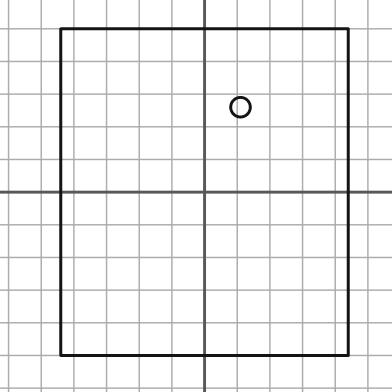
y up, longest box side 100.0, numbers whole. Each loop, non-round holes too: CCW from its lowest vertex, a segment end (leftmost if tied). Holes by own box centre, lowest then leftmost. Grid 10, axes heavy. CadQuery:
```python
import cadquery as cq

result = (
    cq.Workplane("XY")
    .moveTo(-44.0, -50.0)
    .lineTo(44.0, -50.0)
    .lineTo(44.0, 50.0)
    .lineTo(-44.0, 50.0)
    .close()
    .moveTo(11.0, 26.0)
    .circle(3.0)
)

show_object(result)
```